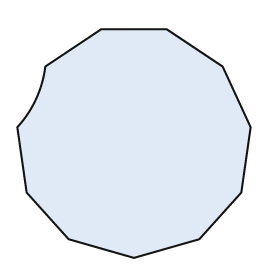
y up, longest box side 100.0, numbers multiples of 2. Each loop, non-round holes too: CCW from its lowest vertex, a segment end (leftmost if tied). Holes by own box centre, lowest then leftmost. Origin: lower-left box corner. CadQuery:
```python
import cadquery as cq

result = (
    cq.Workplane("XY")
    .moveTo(50.0, 0.0)
    .lineTo(78.0, 8.0)
    .lineTo(96.0, 28.0)
    .lineTo(100.0, 56.0)
    .lineTo(88.0, 82.0)
    .lineTo(64.0, 98.0)
    .lineTo(36.0, 98.0)
    .lineTo(12.0, 82.0)
    .threePointArc((8.0, 68.0), (0.0, 56.0))
    .lineTo(4.0, 28.0)
    .lineTo(22.0, 8.0)
    .close()
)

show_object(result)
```